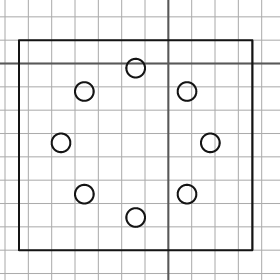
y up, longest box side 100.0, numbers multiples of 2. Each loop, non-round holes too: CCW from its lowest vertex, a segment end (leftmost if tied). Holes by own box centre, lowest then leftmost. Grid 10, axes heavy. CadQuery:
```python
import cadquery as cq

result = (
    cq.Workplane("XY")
    .moveTo(-64.0, -80.0)
    .lineTo(36.0, -80.0)
    .lineTo(36.0, 10.0)
    .lineTo(-64.0, 10.0)
    .close()
    .moveTo(-14.0, -66.0)
    .circle(4.0)
    .moveTo(-36.0, -56.0)
    .circle(4.0)
    .moveTo(8.0, -56.0)
    .circle(4.0)
    .moveTo(-46.0, -34.0)
    .circle(4.0)
    .moveTo(18.0, -34.0)
    .circle(4.0)
    .moveTo(-36.0, -12.0)
    .circle(4.0)
    .moveTo(8.0, -12.0)
    .circle(4.0)
    .moveTo(-14.0, -2.0)
    .circle(4.0)
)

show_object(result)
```